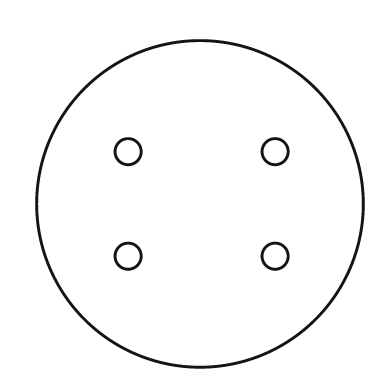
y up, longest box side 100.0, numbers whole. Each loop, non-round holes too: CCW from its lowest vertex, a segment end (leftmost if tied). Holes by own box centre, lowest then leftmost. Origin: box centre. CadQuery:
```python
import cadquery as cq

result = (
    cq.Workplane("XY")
    .moveTo(0.0, 0.0)
    .circle(50.0)
    .moveTo(-22.0, -16.0)
    .circle(4.0)
    .moveTo(23.0, -16.0)
    .circle(4.0)
    .moveTo(-22.0, 16.0)
    .circle(4.0)
    .moveTo(23.0, 16.0)
    .circle(4.0)
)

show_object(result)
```